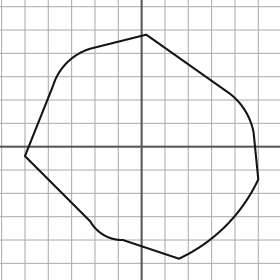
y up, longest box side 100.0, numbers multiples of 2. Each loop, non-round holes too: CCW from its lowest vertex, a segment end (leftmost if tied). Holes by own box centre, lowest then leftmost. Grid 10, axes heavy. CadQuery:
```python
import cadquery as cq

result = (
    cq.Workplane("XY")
    .moveTo(16.0, -48.0)
    .threePointArc((36.0, -34.0), (50.0, -14.0))
    .lineTo(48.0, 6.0)
    .threePointArc((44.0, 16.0), (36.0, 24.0))
    .lineTo(2.0, 48.0)
    .lineTo(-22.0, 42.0)
    .threePointArc((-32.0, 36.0), (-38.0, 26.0))
    .lineTo(-50.0, -4.0)
    .lineTo(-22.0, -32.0)
    .threePointArc((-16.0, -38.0), (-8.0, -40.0))
    .close()
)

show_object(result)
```